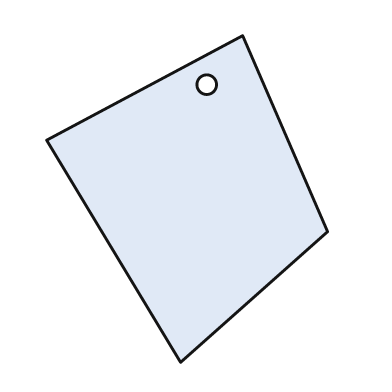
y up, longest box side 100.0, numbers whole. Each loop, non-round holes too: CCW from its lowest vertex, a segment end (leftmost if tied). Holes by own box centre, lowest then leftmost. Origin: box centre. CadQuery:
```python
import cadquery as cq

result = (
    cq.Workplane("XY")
    .moveTo(-2.0, -50.0)
    .lineTo(43.0, -10.0)
    .lineTo(17.0, 50.0)
    .lineTo(-43.0, 18.0)
    .close()
    .moveTo(6.0, 35.0)
    .circle(3.0)
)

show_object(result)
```